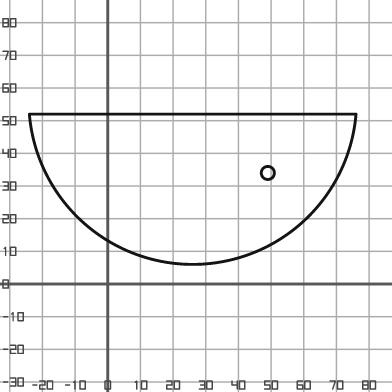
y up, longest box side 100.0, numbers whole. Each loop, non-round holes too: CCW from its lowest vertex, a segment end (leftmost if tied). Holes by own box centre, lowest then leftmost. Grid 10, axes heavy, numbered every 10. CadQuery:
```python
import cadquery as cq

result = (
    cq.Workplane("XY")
    .moveTo(-24.0, 52.0)
    .threePointArc((26.0, 6.0), (76.0, 52.0))
    .close()
    .moveTo(49.0, 34.0)
    .circle(2.0)
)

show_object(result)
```